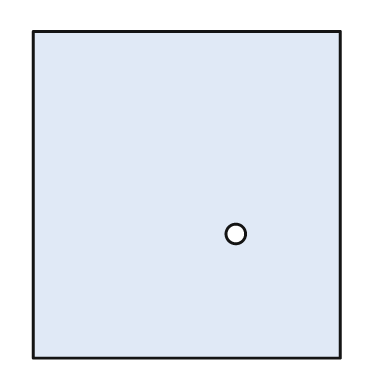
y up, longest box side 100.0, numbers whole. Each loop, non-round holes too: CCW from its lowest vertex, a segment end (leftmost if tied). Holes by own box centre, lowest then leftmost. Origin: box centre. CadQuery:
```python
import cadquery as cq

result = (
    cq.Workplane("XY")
    .moveTo(-47.0, -50.0)
    .lineTo(47.0, -50.0)
    .lineTo(47.0, 50.0)
    .lineTo(-47.0, 50.0)
    .close()
    .moveTo(15.0, -12.0)
    .circle(3.0)
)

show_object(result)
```